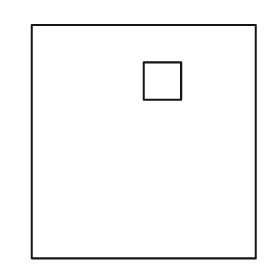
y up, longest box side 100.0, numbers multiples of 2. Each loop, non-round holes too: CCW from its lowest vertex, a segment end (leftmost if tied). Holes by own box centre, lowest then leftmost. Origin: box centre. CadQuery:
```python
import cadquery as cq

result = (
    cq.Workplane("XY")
    .moveTo(-48.0, -50.0)
    .lineTo(48.0, -50.0)
    .lineTo(48.0, 50.0)
    .lineTo(-48.0, 50.0)
    .close()
    .moveTo(0.0, 18.0)
    .lineTo(16.0, 18.0)
    .lineTo(16.0, 34.0)
    .lineTo(0.0, 34.0)
    .close()
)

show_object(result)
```